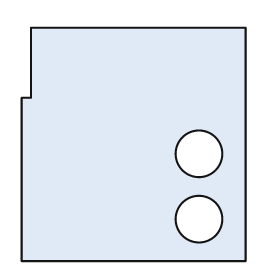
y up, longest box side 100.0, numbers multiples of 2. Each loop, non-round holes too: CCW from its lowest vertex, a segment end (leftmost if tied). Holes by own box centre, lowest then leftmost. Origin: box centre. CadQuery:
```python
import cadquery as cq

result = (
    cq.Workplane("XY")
    .moveTo(-48.0, -50.0)
    .lineTo(48.0, -50.0)
    .lineTo(48.0, 50.0)
    .lineTo(-44.0, 50.0)
    .lineTo(-44.0, 20.0)
    .lineTo(-48.0, 20.0)
    .close()
    .moveTo(28.0, -32.0)
    .circle(10.0)
    .moveTo(28.0, -4.0)
    .circle(10.0)
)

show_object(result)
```